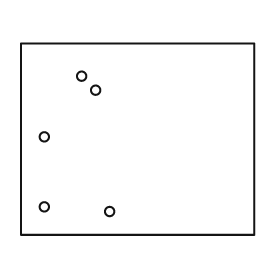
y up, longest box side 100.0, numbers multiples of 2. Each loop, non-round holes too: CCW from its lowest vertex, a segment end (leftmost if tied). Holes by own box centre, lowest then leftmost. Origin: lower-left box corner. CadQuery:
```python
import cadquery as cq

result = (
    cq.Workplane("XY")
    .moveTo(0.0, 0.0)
    .lineTo(100.0, 0.0)
    .lineTo(100.0, 82.0)
    .lineTo(0.0, 82.0)
    .close()
    .moveTo(38.0, 10.0)
    .circle(2.0)
    .moveTo(10.0, 12.0)
    .circle(2.0)
    .moveTo(10.0, 42.0)
    .circle(2.0)
    .moveTo(32.0, 62.0)
    .circle(2.0)
    .moveTo(26.0, 68.0)
    .circle(2.0)
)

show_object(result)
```